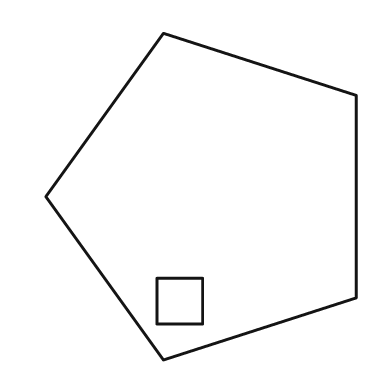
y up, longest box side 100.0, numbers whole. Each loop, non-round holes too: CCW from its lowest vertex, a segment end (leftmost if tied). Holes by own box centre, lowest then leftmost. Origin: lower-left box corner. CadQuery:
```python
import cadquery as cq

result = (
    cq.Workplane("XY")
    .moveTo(36.0, 0.0)
    .lineTo(95.0, 19.0)
    .lineTo(95.0, 81.0)
    .lineTo(36.0, 100.0)
    .lineTo(0.0, 50.0)
    .close()
    .moveTo(34.0, 11.0)
    .lineTo(48.0, 11.0)
    .lineTo(48.0, 25.0)
    .lineTo(34.0, 25.0)
    .close()
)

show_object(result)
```